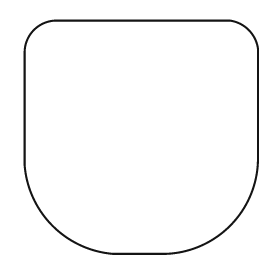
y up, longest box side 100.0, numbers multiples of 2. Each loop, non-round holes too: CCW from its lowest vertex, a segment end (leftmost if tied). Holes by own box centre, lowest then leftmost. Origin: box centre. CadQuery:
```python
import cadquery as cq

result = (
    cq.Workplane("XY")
    .moveTo(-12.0, -50.0)
    .lineTo(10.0, -50.0)
    .threePointArc((38.0, -38.0), (50.0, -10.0))
    .lineTo(50.0, 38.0)
    .threePointArc((46.0, 46.0), (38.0, 50.0))
    .lineTo(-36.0, 50.0)
    .threePointArc((-46.0, 46.0), (-50.0, 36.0))
    .lineTo(-50.0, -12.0)
    .threePointArc((-38.0, -38.0), (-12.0, -50.0))
    .close()
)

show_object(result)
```